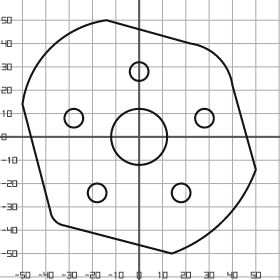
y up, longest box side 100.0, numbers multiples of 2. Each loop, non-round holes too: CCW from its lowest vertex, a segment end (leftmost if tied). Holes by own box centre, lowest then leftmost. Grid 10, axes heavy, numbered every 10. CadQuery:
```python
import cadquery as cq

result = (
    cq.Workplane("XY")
    .moveTo(14.0, -50.0)
    .threePointArc((36.0, -36.0), (50.0, -14.0))
    .lineTo(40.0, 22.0)
    .threePointArc((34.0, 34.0), (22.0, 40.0))
    .lineTo(-14.0, 50.0)
    .threePointArc((-38.0, 38.0), (-50.0, 14.0))
    .lineTo(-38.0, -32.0)
    .threePointArc((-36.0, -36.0), (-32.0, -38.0))
    .close()
    .moveTo(-18.0, -24.0)
    .circle(4.0)
    .moveTo(18.0, -24.0)
    .circle(4.0)
    .moveTo(0.0, 0.0)
    .circle(12.0)
    .moveTo(-28.0, 8.0)
    .circle(4.0)
    .moveTo(28.0, 8.0)
    .circle(4.0)
    .moveTo(0.0, 28.0)
    .circle(4.0)
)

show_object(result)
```